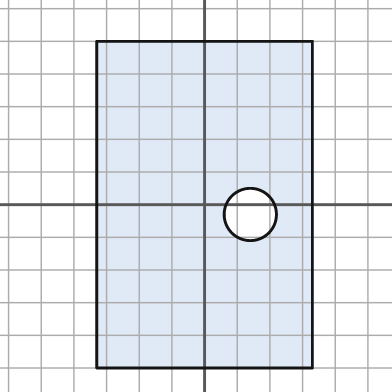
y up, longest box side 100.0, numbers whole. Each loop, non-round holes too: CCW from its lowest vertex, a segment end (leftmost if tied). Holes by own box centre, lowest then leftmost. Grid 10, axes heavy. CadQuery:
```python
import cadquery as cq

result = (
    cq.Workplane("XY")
    .moveTo(-33.0, -50.0)
    .lineTo(33.0, -50.0)
    .lineTo(33.0, 50.0)
    .lineTo(-33.0, 50.0)
    .close()
    .moveTo(14.0, -3.0)
    .circle(8.0)
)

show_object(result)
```